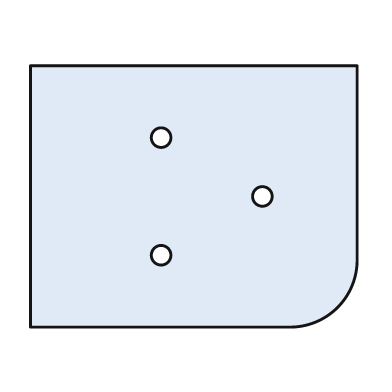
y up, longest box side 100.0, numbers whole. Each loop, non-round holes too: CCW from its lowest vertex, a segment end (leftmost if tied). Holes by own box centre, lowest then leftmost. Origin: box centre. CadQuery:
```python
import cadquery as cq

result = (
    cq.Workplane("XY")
    .moveTo(-50.0, -40.0)
    .lineTo(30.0, -40.0)
    .threePointArc((44.0, -34.0), (50.0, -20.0))
    .lineTo(50.0, 40.0)
    .lineTo(-50.0, 40.0)
    .close()
    .moveTo(-10.0, -18.0)
    .circle(3.0)
    .moveTo(21.0, 0.0)
    .circle(3.0)
    .moveTo(-10.0, 18.0)
    .circle(3.0)
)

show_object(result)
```